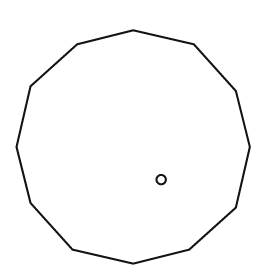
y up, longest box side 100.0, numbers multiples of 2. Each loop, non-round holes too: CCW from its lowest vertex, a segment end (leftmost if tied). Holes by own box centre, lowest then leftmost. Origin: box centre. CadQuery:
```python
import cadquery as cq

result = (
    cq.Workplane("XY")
    .moveTo(0.0, -50.0)
    .lineTo(24.0, -44.0)
    .lineTo(44.0, -26.0)
    .lineTo(50.0, 0.0)
    .lineTo(44.0, 24.0)
    .lineTo(26.0, 44.0)
    .lineTo(0.0, 50.0)
    .lineTo(-24.0, 44.0)
    .lineTo(-44.0, 26.0)
    .lineTo(-50.0, 0.0)
    .lineTo(-44.0, -24.0)
    .lineTo(-26.0, -44.0)
    .close()
    .moveTo(12.0, -14.0)
    .circle(2.0)
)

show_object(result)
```